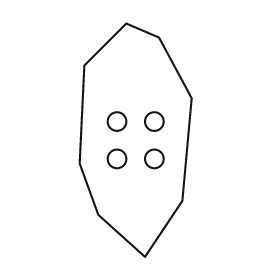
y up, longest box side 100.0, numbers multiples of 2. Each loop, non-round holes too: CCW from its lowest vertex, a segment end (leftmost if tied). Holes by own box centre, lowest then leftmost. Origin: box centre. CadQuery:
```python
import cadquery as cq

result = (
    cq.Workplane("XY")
    .moveTo(4.0, -50.0)
    .lineTo(20.0, -26.0)
    .lineTo(24.0, 18.0)
    .lineTo(10.0, 44.0)
    .lineTo(-4.0, 50.0)
    .lineTo(-22.0, 32.0)
    .lineTo(-24.0, -10.0)
    .lineTo(-16.0, -32.0)
    .close()
    .moveTo(-8.0, -8.0)
    .circle(4.0)
    .moveTo(8.0, -8.0)
    .circle(4.0)
    .moveTo(-8.0, 8.0)
    .circle(4.0)
    .moveTo(8.0, 8.0)
    .circle(4.0)
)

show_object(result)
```